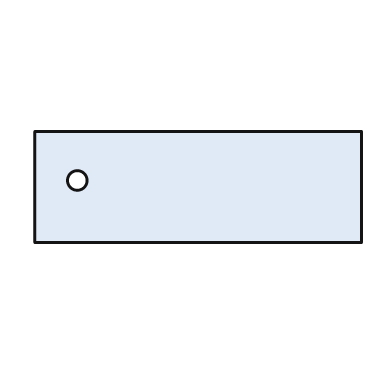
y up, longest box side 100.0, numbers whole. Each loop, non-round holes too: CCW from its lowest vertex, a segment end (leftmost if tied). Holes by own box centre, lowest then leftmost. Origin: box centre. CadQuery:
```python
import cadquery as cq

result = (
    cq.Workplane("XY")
    .moveTo(-50.0, -17.0)
    .lineTo(50.0, -17.0)
    .lineTo(50.0, 17.0)
    .lineTo(-50.0, 17.0)
    .close()
    .moveTo(-37.0, 2.0)
    .circle(3.0)
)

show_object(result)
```